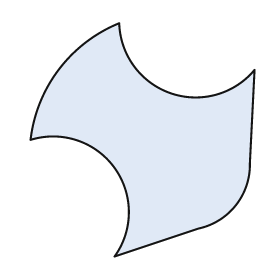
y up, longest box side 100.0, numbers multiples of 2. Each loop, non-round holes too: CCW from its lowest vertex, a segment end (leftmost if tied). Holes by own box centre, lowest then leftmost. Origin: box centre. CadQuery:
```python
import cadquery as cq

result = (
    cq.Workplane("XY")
    .moveTo(-12.0, -50.0)
    .lineTo(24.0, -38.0)
    .threePointArc((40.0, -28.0), (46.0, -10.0))
    .lineTo(48.0, 30.0)
    .threePointArc((12.0, 20.0), (-10.0, 50.0))
    .threePointArc((-36.0, 30.0), (-48.0, 0.0))
    .threePointArc((-12.0, -12.0), (-12.0, -50.0))
    .close()
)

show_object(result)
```